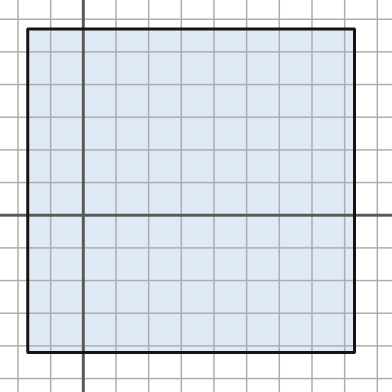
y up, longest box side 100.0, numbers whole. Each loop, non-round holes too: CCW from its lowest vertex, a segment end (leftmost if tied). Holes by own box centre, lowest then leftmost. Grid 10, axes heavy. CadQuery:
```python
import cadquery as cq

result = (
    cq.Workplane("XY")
    .moveTo(-17.0, -42.0)
    .lineTo(83.0, -42.0)
    .lineTo(83.0, 57.0)
    .lineTo(-17.0, 57.0)
    .close()
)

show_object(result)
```